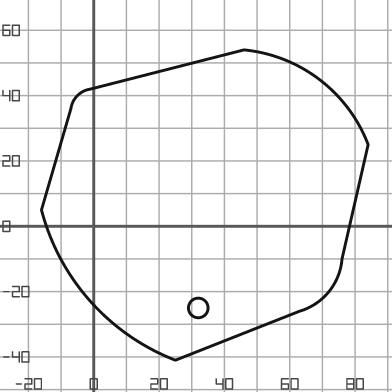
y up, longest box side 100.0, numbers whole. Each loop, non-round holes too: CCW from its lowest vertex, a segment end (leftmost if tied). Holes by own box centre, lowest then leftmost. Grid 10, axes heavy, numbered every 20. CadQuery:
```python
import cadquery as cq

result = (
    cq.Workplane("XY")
    .moveTo(25.0, -41.0)
    .lineTo(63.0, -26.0)
    .threePointArc((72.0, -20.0), (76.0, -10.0))
    .lineTo(84.0, 25.0)
    .threePointArc((69.0, 45.0), (46.0, 54.0))
    .lineTo(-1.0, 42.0)
    .threePointArc((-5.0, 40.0), (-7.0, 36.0))
    .lineTo(-16.0, 5.0)
    .threePointArc((-1.0, -23.0), (25.0, -41.0))
    .close()
    .moveTo(32.0, -25.0)
    .circle(3.0)
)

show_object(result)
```